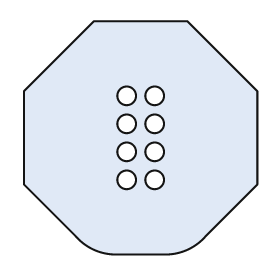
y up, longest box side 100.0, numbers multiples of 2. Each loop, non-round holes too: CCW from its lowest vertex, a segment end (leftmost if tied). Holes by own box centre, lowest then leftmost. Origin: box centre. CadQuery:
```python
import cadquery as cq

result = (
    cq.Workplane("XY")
    .moveTo(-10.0, -50.0)
    .lineTo(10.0, -50.0)
    .threePointArc((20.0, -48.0), (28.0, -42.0))
    .lineTo(50.0, -20.0)
    .lineTo(50.0, 20.0)
    .lineTo(20.0, 50.0)
    .lineTo(-20.0, 50.0)
    .lineTo(-50.0, 20.0)
    .lineTo(-50.0, -20.0)
    .lineTo(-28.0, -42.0)
    .threePointArc((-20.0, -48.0), (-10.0, -50.0))
    .close()
    .moveTo(-6.0, -18.0)
    .circle(4.0)
    .moveTo(6.0, -18.0)
    .circle(4.0)
    .moveTo(-6.0, -6.0)
    .circle(4.0)
    .moveTo(6.0, -6.0)
    .circle(4.0)
    .moveTo(-6.0, 6.0)
    .circle(4.0)
    .moveTo(6.0, 6.0)
    .circle(4.0)
    .moveTo(-6.0, 18.0)
    .circle(4.0)
    .moveTo(6.0, 18.0)
    .circle(4.0)
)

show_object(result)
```